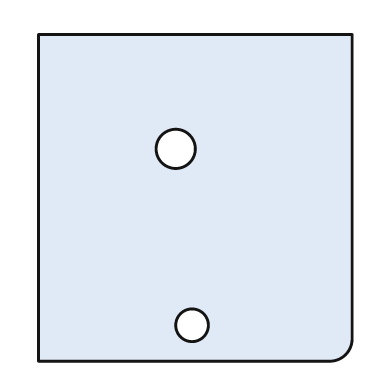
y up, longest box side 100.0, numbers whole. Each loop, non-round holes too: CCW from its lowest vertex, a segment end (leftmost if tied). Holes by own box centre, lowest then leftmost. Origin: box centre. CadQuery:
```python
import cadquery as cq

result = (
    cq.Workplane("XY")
    .moveTo(-48.0, -50.0)
    .lineTo(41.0, -50.0)
    .threePointArc((46.0, -48.0), (48.0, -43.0))
    .lineTo(48.0, 50.0)
    .lineTo(-48.0, 50.0)
    .close()
    .moveTo(-1.0, -39.0)
    .circle(5.0)
    .moveTo(-6.0, 15.0)
    .circle(6.0)
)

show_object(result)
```